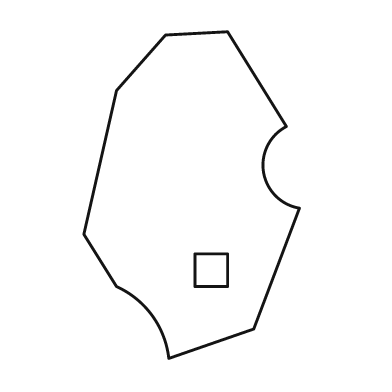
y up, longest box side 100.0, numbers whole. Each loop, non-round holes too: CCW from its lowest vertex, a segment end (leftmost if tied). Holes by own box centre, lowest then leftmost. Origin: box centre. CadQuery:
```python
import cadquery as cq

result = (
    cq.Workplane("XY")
    .moveTo(-7.0, -50.0)
    .lineTo(19.0, -41.0)
    .lineTo(33.0, -4.0)
    .threePointArc((22.0, 7.0), (29.0, 21.0))
    .lineTo(11.0, 50.0)
    .lineTo(-8.0, 49.0)
    .lineTo(-23.0, 32.0)
    .lineTo(-33.0, -12.0)
    .lineTo(-23.0, -28.0)
    .threePointArc((-12.0, -37.0), (-7.0, -50.0))
    .close()
    .moveTo(1.0, -28.0)
    .lineTo(11.0, -28.0)
    .lineTo(11.0, -18.0)
    .lineTo(1.0, -18.0)
    .close()
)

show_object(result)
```